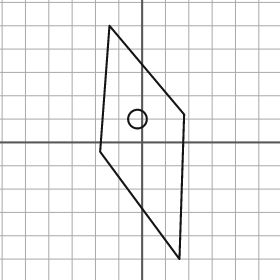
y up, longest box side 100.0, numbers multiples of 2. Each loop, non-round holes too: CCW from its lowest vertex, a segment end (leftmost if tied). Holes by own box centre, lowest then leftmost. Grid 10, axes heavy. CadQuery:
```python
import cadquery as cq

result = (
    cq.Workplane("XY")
    .moveTo(16.0, -50.0)
    .lineTo(18.0, 12.0)
    .lineTo(-14.0, 50.0)
    .lineTo(-18.0, -4.0)
    .close()
    .moveTo(-2.0, 10.0)
    .circle(4.0)
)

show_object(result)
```